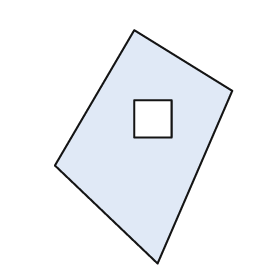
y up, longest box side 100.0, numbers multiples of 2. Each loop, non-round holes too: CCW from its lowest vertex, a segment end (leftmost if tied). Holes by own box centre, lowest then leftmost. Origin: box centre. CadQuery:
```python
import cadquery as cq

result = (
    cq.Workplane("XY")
    .moveTo(6.0, -50.0)
    .lineTo(38.0, 24.0)
    .lineTo(-4.0, 50.0)
    .lineTo(-38.0, -8.0)
    .close()
    .moveTo(-4.0, 4.0)
    .lineTo(12.0, 4.0)
    .lineTo(12.0, 20.0)
    .lineTo(-4.0, 20.0)
    .close()
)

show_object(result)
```